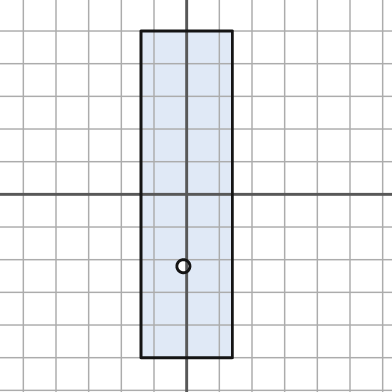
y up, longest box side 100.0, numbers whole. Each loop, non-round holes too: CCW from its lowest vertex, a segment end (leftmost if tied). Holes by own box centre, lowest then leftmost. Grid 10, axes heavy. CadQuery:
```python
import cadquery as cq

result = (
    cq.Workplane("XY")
    .moveTo(-14.0, -50.0)
    .lineTo(14.0, -50.0)
    .lineTo(14.0, 50.0)
    .lineTo(-14.0, 50.0)
    .close()
    .moveTo(-1.0, -22.0)
    .circle(2.0)
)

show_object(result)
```